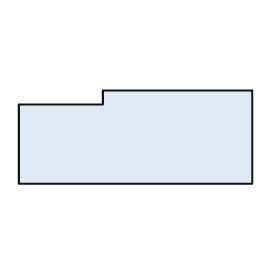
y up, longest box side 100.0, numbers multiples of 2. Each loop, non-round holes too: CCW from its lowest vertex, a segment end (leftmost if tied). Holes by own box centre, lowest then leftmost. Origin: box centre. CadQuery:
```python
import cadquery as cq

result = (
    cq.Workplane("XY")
    .moveTo(-50.0, -20.0)
    .lineTo(50.0, -20.0)
    .lineTo(50.0, 20.0)
    .lineTo(-14.0, 20.0)
    .lineTo(-14.0, 14.0)
    .lineTo(-50.0, 14.0)
    .close()
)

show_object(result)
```